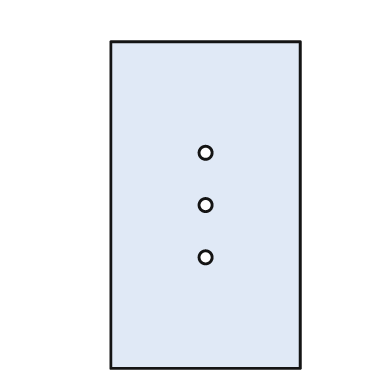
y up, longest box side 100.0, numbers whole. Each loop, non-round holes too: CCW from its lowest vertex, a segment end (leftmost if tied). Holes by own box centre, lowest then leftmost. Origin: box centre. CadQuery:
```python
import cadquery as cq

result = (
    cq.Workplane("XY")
    .moveTo(-29.0, -50.0)
    .lineTo(29.0, -50.0)
    .lineTo(29.0, 50.0)
    .lineTo(-29.0, 50.0)
    .close()
    .moveTo(0.0, -16.0)
    .circle(2.0)
    .moveTo(0.0, 0.0)
    .circle(2.0)
    .moveTo(0.0, 16.0)
    .circle(2.0)
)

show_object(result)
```